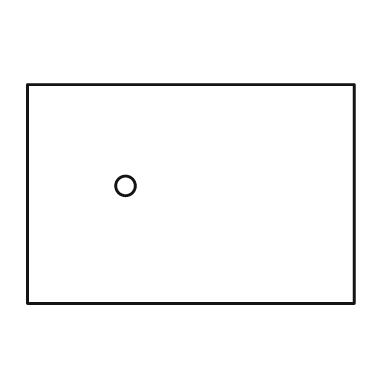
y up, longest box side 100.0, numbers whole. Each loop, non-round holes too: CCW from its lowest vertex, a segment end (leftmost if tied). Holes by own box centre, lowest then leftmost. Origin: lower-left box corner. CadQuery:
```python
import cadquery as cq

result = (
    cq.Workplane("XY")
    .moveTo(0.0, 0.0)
    .lineTo(100.0, 0.0)
    .lineTo(100.0, 67.0)
    .lineTo(0.0, 67.0)
    .close()
    .moveTo(30.0, 36.0)
    .circle(3.0)
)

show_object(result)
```